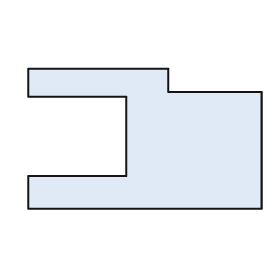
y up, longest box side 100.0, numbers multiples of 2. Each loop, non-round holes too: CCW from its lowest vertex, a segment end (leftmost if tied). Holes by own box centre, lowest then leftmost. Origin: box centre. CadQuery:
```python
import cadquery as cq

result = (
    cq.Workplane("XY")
    .moveTo(-50.0, -30.0)
    .lineTo(50.0, -30.0)
    .lineTo(50.0, 20.0)
    .lineTo(10.0, 20.0)
    .lineTo(10.0, 30.0)
    .lineTo(-50.0, 30.0)
    .lineTo(-50.0, 18.0)
    .lineTo(-8.0, 18.0)
    .lineTo(-8.0, -16.0)
    .lineTo(-50.0, -16.0)
    .close()
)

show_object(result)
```